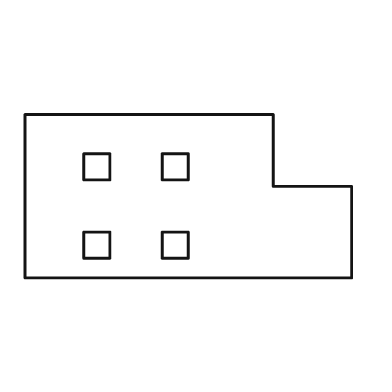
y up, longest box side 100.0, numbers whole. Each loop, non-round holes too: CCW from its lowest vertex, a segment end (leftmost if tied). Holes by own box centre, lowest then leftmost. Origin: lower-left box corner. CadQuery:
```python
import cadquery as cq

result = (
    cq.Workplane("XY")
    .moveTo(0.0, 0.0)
    .lineTo(100.0, 0.0)
    .lineTo(100.0, 28.0)
    .lineTo(76.0, 28.0)
    .lineTo(76.0, 50.0)
    .lineTo(0.0, 50.0)
    .close()
    .moveTo(18.0, 6.0)
    .lineTo(26.0, 6.0)
    .lineTo(26.0, 14.0)
    .lineTo(18.0, 14.0)
    .close()
    .moveTo(42.0, 6.0)
    .lineTo(50.0, 6.0)
    .lineTo(50.0, 14.0)
    .lineTo(42.0, 14.0)
    .close()
    .moveTo(18.0, 30.0)
    .lineTo(26.0, 30.0)
    .lineTo(26.0, 38.0)
    .lineTo(18.0, 38.0)
    .close()
    .moveTo(42.0, 30.0)
    .lineTo(50.0, 30.0)
    .lineTo(50.0, 38.0)
    .lineTo(42.0, 38.0)
    .close()
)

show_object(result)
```